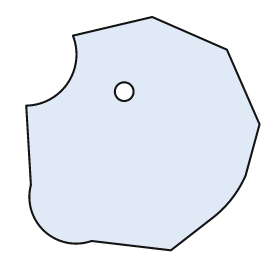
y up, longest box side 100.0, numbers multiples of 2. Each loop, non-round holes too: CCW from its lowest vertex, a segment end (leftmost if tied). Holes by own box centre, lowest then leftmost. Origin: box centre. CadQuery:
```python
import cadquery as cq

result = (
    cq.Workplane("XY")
    .moveTo(12.0, -50.0)
    .lineTo(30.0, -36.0)
    .threePointArc((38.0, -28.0), (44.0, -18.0))
    .lineTo(50.0, 4.0)
    .lineTo(36.0, 36.0)
    .lineTo(4.0, 50.0)
    .lineTo(-30.0, 42.0)
    .threePointArc((-32.0, 22.0), (-50.0, 12.0))
    .lineTo(-48.0, -22.0)
    .threePointArc((-42.0, -42.0), (-22.0, -46.0))
    .close()
    .moveTo(-8.0, 18.0)
    .circle(4.0)
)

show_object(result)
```